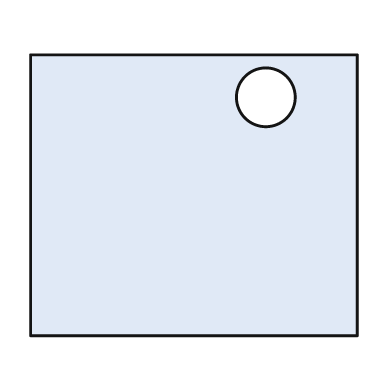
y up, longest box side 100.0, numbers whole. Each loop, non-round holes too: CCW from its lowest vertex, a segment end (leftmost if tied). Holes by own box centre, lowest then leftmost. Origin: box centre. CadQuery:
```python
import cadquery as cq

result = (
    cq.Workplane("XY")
    .moveTo(-50.0, -43.0)
    .lineTo(50.0, -43.0)
    .lineTo(50.0, 43.0)
    .lineTo(-50.0, 43.0)
    .close()
    .moveTo(22.0, 30.0)
    .circle(9.0)
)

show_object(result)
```